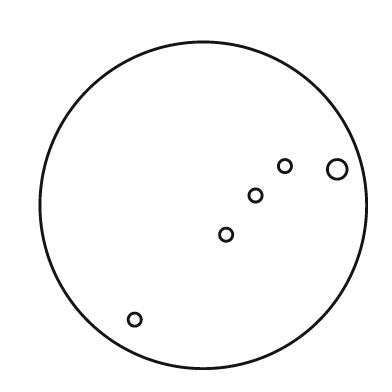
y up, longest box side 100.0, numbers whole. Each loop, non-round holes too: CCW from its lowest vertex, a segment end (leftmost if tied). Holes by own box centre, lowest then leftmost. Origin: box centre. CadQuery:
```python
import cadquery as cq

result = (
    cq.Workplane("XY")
    .moveTo(0.0, 0.0)
    .circle(50.0)
    .moveTo(-21.0, -35.0)
    .circle(2.0)
    .moveTo(7.0, -9.0)
    .circle(2.0)
    .moveTo(16.0, 3.0)
    .circle(2.0)
    .moveTo(41.0, 11.0)
    .circle(3.0)
    .moveTo(25.0, 12.0)
    .circle(2.0)
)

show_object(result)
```